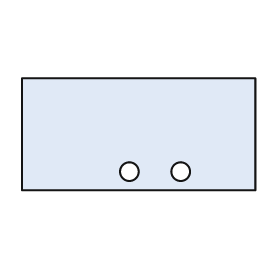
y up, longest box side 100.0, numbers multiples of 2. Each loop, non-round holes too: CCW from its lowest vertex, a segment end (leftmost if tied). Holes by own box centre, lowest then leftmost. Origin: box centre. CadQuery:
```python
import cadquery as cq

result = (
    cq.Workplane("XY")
    .moveTo(-50.0, -24.0)
    .lineTo(50.0, -24.0)
    .lineTo(50.0, 24.0)
    .lineTo(-50.0, 24.0)
    .close()
    .moveTo(-4.0, -16.0)
    .circle(4.0)
    .moveTo(18.0, -16.0)
    .circle(4.0)
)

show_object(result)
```